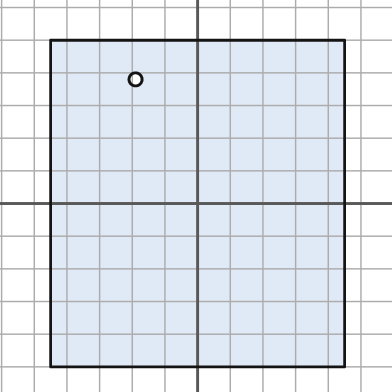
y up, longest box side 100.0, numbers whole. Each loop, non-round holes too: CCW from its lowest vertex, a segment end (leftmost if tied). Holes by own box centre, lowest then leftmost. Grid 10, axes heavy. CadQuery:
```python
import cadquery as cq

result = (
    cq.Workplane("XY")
    .moveTo(-45.0, -50.0)
    .lineTo(45.0, -50.0)
    .lineTo(45.0, 50.0)
    .lineTo(-45.0, 50.0)
    .close()
    .moveTo(-19.0, 38.0)
    .circle(2.0)
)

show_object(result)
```